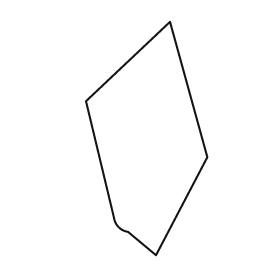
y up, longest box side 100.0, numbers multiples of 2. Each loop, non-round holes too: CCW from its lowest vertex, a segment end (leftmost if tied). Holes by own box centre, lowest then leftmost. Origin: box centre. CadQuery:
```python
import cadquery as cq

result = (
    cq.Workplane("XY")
    .moveTo(4.0, -50.0)
    .lineTo(26.0, -8.0)
    .lineTo(10.0, 50.0)
    .lineTo(-26.0, 16.0)
    .lineTo(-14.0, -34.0)
    .threePointArc((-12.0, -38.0), (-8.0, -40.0))
    .close()
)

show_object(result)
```